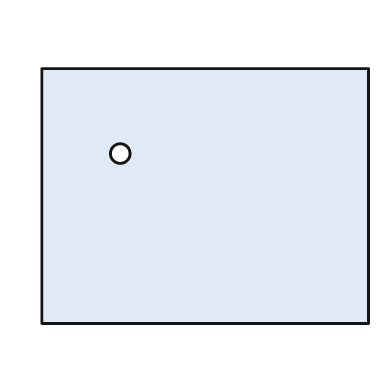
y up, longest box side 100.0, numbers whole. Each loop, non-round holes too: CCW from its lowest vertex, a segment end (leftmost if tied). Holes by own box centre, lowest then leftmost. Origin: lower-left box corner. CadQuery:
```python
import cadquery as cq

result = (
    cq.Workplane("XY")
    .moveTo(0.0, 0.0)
    .lineTo(100.0, 0.0)
    .lineTo(100.0, 78.0)
    .lineTo(0.0, 78.0)
    .close()
    .moveTo(24.0, 52.0)
    .circle(3.0)
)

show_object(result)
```